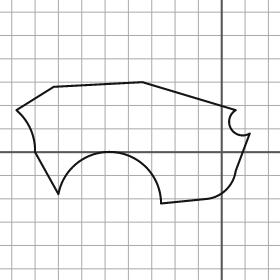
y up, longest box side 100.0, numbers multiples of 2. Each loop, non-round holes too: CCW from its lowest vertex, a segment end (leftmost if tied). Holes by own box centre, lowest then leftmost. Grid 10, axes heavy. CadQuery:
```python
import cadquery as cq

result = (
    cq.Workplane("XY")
    .moveTo(-26.0, -22.0)
    .lineTo(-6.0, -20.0)
    .threePointArc((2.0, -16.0), (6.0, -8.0))
    .lineTo(12.0, 8.0)
    .threePointArc((4.0, 10.0), (6.0, 18.0))
    .lineTo(-34.0, 30.0)
    .lineTo(-72.0, 28.0)
    .lineTo(-88.0, 18.0)
    .threePointArc((-82.0, 10.0), (-80.0, 0.0))
    .lineTo(-70.0, -18.0)
    .threePointArc((-46.0, 0.0), (-26.0, -22.0))
    .close()
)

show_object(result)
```